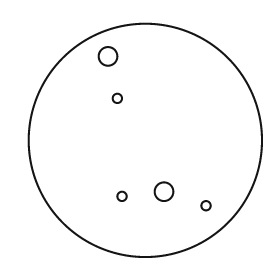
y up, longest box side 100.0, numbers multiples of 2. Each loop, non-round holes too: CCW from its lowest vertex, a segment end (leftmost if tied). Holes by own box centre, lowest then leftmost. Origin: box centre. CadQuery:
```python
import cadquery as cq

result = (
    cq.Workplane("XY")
    .moveTo(0.0, 0.0)
    .circle(50.0)
    .moveTo(26.0, -28.0)
    .circle(2.0)
    .moveTo(-10.0, -24.0)
    .circle(2.0)
    .moveTo(8.0, -22.0)
    .circle(4.0)
    .moveTo(-12.0, 18.0)
    .circle(2.0)
    .moveTo(-16.0, 36.0)
    .circle(4.0)
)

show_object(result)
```